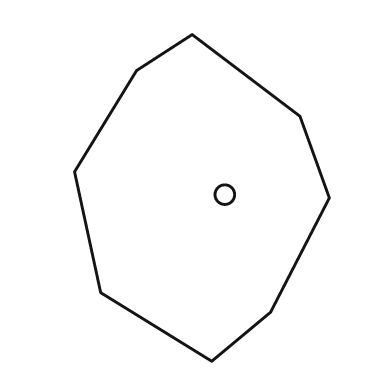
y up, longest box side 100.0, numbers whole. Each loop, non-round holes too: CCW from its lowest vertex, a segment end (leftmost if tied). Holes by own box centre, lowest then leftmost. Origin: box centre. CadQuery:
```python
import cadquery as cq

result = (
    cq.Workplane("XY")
    .moveTo(3.0, -50.0)
    .lineTo(21.0, -35.0)
    .lineTo(39.0, 0.0)
    .lineTo(30.0, 25.0)
    .lineTo(-3.0, 50.0)
    .lineTo(-20.0, 39.0)
    .lineTo(-39.0, 8.0)
    .lineTo(-31.0, -29.0)
    .close()
    .moveTo(7.0, 1.0)
    .circle(3.0)
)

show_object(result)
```